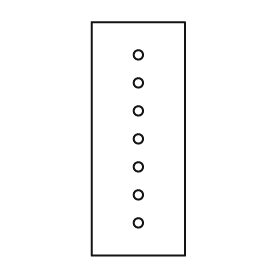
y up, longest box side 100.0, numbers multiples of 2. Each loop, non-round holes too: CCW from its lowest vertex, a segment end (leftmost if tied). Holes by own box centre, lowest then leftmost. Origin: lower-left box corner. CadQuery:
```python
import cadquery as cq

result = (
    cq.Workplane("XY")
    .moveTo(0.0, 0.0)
    .lineTo(40.0, 0.0)
    .lineTo(40.0, 100.0)
    .lineTo(0.0, 100.0)
    .close()
    .moveTo(20.0, 14.0)
    .circle(2.0)
    .moveTo(20.0, 26.0)
    .circle(2.0)
    .moveTo(20.0, 38.0)
    .circle(2.0)
    .moveTo(20.0, 50.0)
    .circle(2.0)
    .moveTo(20.0, 62.0)
    .circle(2.0)
    .moveTo(20.0, 74.0)
    .circle(2.0)
    .moveTo(20.0, 86.0)
    .circle(2.0)
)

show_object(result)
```